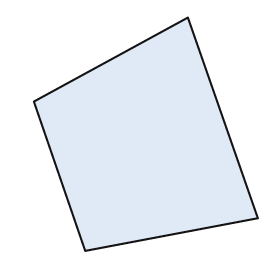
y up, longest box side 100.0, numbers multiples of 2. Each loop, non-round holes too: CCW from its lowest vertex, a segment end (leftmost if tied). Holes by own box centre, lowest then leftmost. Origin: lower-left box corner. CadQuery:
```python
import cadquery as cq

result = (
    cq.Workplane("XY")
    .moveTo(22.0, 0.0)
    .lineTo(96.0, 14.0)
    .lineTo(66.0, 100.0)
    .lineTo(0.0, 64.0)
    .close()
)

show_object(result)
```